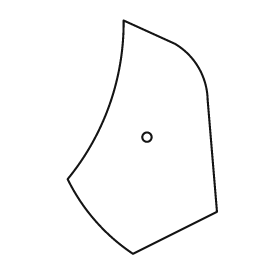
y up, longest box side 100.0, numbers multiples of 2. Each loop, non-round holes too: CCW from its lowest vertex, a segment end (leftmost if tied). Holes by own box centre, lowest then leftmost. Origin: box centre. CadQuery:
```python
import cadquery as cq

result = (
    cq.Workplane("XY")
    .moveTo(-4.0, -50.0)
    .lineTo(32.0, -32.0)
    .lineTo(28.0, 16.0)
    .threePointArc((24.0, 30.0), (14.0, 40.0))
    .lineTo(-8.0, 50.0)
    .threePointArc((-14.0, 14.0), (-32.0, -18.0))
    .threePointArc((-20.0, -36.0), (-4.0, -50.0))
    .close()
    .moveTo(2.0, 0.0)
    .circle(2.0)
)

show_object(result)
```